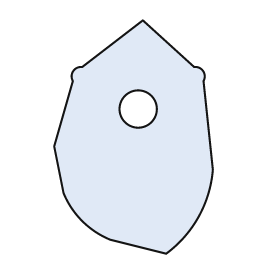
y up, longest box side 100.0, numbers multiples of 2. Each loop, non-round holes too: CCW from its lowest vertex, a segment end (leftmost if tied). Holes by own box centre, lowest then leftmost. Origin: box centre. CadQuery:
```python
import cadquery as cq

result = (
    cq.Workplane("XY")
    .moveTo(14.0, -50.0)
    .threePointArc((28.0, -34.0), (34.0, -14.0))
    .lineTo(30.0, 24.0)
    .threePointArc((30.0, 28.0), (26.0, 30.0))
    .lineTo(4.0, 50.0)
    .lineTo(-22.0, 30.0)
    .threePointArc((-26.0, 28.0), (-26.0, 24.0))
    .lineTo(-34.0, -4.0)
    .lineTo(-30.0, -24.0)
    .threePointArc((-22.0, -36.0), (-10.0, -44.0))
    .close()
    .moveTo(2.0, 12.0)
    .circle(8.0)
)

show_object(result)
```